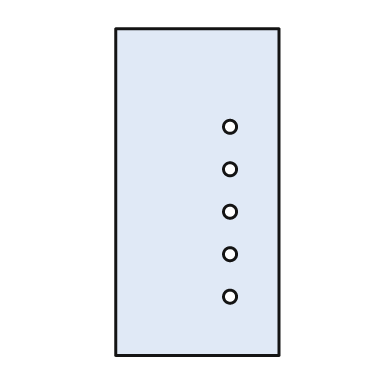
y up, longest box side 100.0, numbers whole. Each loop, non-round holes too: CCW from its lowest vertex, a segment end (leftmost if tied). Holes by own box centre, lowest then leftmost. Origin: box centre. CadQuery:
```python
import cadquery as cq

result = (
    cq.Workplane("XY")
    .moveTo(-25.0, -50.0)
    .lineTo(25.0, -50.0)
    .lineTo(25.0, 50.0)
    .lineTo(-25.0, 50.0)
    .close()
    .moveTo(10.0, -32.0)
    .circle(2.0)
    .moveTo(10.0, -19.0)
    .circle(2.0)
    .moveTo(10.0, -6.0)
    .circle(2.0)
    .moveTo(10.0, 7.0)
    .circle(2.0)
    .moveTo(10.0, 20.0)
    .circle(2.0)
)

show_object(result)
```